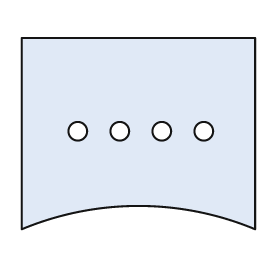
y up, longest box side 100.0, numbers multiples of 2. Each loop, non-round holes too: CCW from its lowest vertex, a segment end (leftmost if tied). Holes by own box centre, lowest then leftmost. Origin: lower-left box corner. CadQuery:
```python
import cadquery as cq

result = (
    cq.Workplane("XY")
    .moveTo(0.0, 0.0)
    .threePointArc((50.0, 10.0), (100.0, 0.0))
    .lineTo(100.0, 82.0)
    .lineTo(0.0, 82.0)
    .close()
    .moveTo(24.0, 42.0)
    .circle(4.0)
    .moveTo(42.0, 42.0)
    .circle(4.0)
    .moveTo(60.0, 42.0)
    .circle(4.0)
    .moveTo(78.0, 42.0)
    .circle(4.0)
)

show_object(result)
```